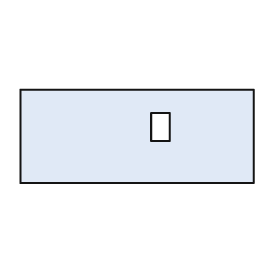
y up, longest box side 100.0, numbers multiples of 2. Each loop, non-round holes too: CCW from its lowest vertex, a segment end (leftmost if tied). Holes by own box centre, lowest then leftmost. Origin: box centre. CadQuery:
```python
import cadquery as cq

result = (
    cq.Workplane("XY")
    .moveTo(-50.0, -20.0)
    .lineTo(50.0, -20.0)
    .lineTo(50.0, 20.0)
    .lineTo(-50.0, 20.0)
    .close()
    .moveTo(6.0, -2.0)
    .lineTo(14.0, -2.0)
    .lineTo(14.0, 10.0)
    .lineTo(6.0, 10.0)
    .close()
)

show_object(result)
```